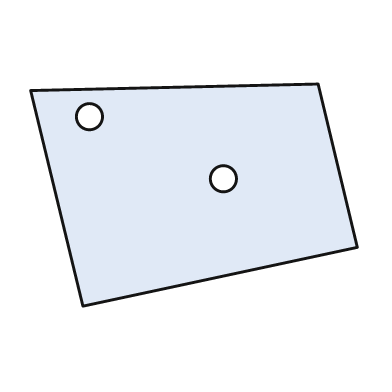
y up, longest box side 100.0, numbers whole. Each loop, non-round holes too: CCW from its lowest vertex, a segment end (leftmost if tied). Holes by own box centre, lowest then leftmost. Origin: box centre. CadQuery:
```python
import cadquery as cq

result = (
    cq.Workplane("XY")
    .moveTo(-34.0, -34.0)
    .lineTo(50.0, -16.0)
    .lineTo(38.0, 34.0)
    .lineTo(-50.0, 32.0)
    .close()
    .moveTo(9.0, 5.0)
    .circle(4.0)
    .moveTo(-32.0, 24.0)
    .circle(4.0)
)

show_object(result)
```